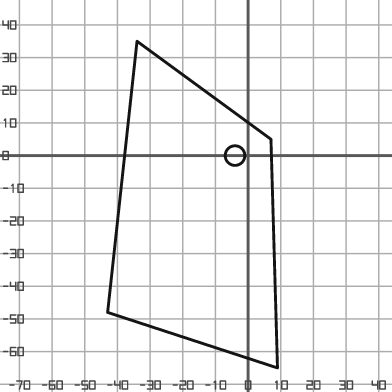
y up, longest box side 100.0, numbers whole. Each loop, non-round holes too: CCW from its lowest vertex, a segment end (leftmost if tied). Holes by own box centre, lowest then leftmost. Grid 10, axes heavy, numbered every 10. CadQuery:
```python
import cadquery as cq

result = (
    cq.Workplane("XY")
    .moveTo(9.0, -65.0)
    .lineTo(7.0, 5.0)
    .lineTo(-34.0, 35.0)
    .lineTo(-43.0, -48.0)
    .close()
    .moveTo(-4.0, 0.0)
    .circle(3.0)
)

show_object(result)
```